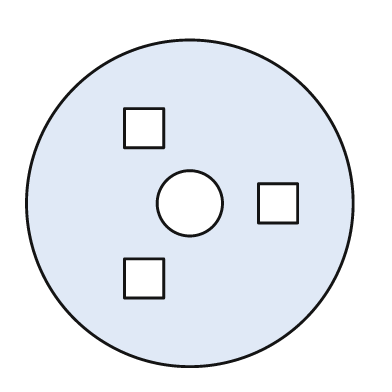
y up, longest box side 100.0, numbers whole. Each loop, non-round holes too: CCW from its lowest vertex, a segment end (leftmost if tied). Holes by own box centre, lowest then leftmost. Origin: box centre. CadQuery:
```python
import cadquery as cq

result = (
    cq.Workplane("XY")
    .moveTo(0.0, 0.0)
    .circle(50.0)
    .moveTo(-20.0, -29.0)
    .lineTo(-8.0, -29.0)
    .lineTo(-8.0, -17.0)
    .lineTo(-20.0, -17.0)
    .close()
    .moveTo(0.0, 0.0)
    .circle(10.0)
    .moveTo(21.0, -6.0)
    .lineTo(33.0, -6.0)
    .lineTo(33.0, 6.0)
    .lineTo(21.0, 6.0)
    .close()
    .moveTo(-20.0, 17.0)
    .lineTo(-8.0, 17.0)
    .lineTo(-8.0, 29.0)
    .lineTo(-20.0, 29.0)
    .close()
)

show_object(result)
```